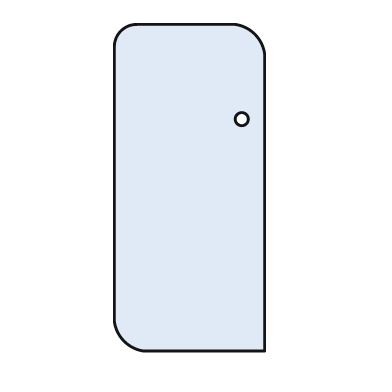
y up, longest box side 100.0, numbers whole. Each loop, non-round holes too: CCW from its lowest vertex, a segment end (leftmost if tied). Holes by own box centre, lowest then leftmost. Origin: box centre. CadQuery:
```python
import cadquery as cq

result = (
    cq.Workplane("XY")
    .moveTo(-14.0, -50.0)
    .lineTo(23.0, -50.0)
    .lineTo(23.0, 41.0)
    .threePointArc((20.0, 47.0), (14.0, 50.0))
    .lineTo(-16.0, 50.0)
    .threePointArc((-21.0, 48.0), (-23.0, 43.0))
    .lineTo(-23.0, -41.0)
    .threePointArc((-20.0, -47.0), (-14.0, -50.0))
    .close()
    .moveTo(16.0, 21.0)
    .circle(2.0)
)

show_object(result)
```